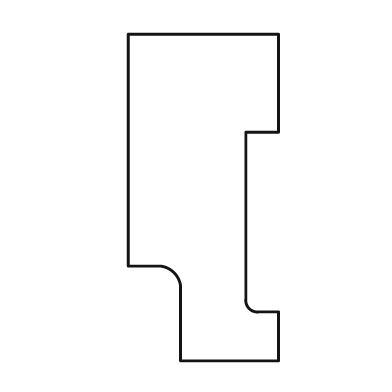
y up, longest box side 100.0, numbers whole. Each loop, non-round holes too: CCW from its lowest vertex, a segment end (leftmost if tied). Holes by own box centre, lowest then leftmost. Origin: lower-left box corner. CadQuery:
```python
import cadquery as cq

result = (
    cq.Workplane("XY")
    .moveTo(16.0, 0.0)
    .lineTo(46.0, 0.0)
    .lineTo(46.0, 15.0)
    .lineTo(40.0, 15.0)
    .threePointArc((37.0, 16.0), (36.0, 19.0))
    .lineTo(36.0, 70.0)
    .lineTo(46.0, 70.0)
    .lineTo(46.0, 100.0)
    .lineTo(0.0, 100.0)
    .lineTo(0.0, 29.0)
    .lineTo(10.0, 29.0)
    .threePointArc((14.0, 27.0), (16.0, 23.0))
    .close()
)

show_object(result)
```